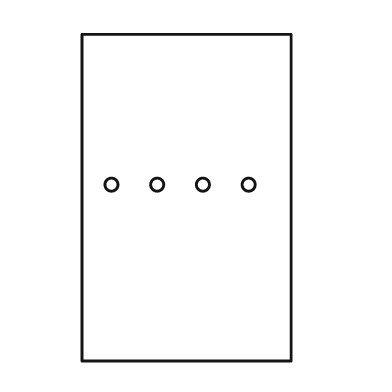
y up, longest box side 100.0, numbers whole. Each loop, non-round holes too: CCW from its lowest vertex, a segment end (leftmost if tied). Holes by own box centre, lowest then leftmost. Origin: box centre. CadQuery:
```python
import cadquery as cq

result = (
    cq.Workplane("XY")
    .moveTo(-32.0, -50.0)
    .lineTo(32.0, -50.0)
    .lineTo(32.0, 50.0)
    .lineTo(-32.0, 50.0)
    .close()
    .moveTo(-23.0, 4.0)
    .circle(2.0)
    .moveTo(-9.0, 4.0)
    .circle(2.0)
    .moveTo(5.0, 4.0)
    .circle(2.0)
    .moveTo(19.0, 4.0)
    .circle(2.0)
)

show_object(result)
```